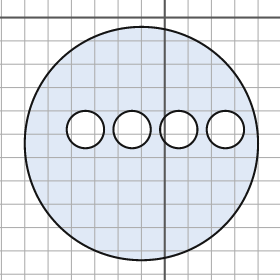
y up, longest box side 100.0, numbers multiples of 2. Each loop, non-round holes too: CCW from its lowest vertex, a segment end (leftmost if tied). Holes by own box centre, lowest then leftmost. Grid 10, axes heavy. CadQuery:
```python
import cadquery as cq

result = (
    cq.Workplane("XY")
    .moveTo(-10.0, -54.0)
    .circle(50.0)
    .moveTo(-34.0, -48.0)
    .circle(8.0)
    .moveTo(-14.0, -48.0)
    .circle(8.0)
    .moveTo(6.0, -48.0)
    .circle(8.0)
    .moveTo(26.0, -48.0)
    .circle(8.0)
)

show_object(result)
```